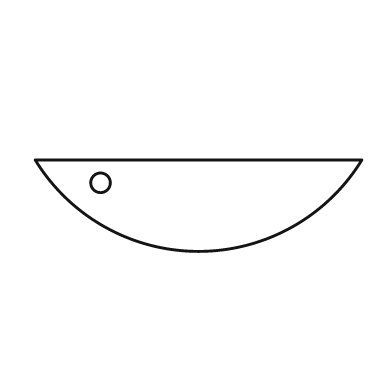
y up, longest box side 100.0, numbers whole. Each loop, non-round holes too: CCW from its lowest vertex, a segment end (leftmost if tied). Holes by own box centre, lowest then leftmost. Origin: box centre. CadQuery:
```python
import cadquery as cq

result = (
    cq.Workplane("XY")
    .moveTo(-50.0, 14.0)
    .threePointArc((0.0, -14.0), (50.0, 14.0))
    .close()
    .moveTo(-30.0, 7.0)
    .circle(3.0)
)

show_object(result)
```